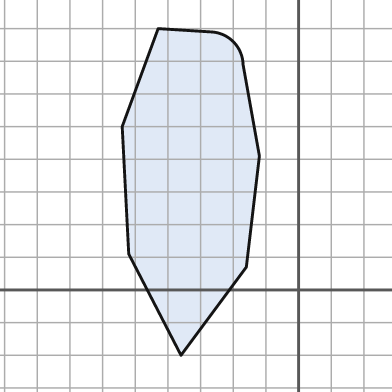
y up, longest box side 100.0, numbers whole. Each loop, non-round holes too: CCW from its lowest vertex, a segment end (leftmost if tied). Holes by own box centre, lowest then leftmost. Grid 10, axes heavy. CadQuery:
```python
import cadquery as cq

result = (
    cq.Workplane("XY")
    .moveTo(-36.0, -20.0)
    .lineTo(-16.0, 7.0)
    .lineTo(-12.0, 41.0)
    .lineTo(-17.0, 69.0)
    .threePointArc((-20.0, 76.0), (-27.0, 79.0))
    .lineTo(-43.0, 80.0)
    .lineTo(-54.0, 50.0)
    .lineTo(-52.0, 11.0)
    .close()
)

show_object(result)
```